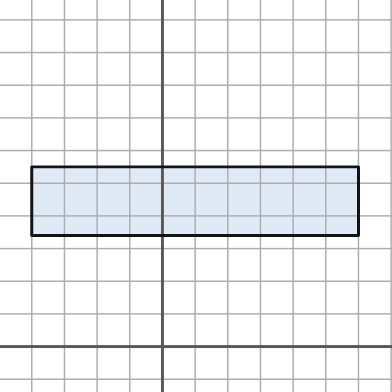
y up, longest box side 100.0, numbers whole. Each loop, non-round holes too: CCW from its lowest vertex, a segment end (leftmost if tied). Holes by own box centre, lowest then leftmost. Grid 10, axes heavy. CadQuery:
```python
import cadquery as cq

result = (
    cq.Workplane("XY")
    .moveTo(-40.0, 34.0)
    .lineTo(60.0, 34.0)
    .lineTo(60.0, 55.0)
    .lineTo(-40.0, 55.0)
    .close()
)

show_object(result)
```